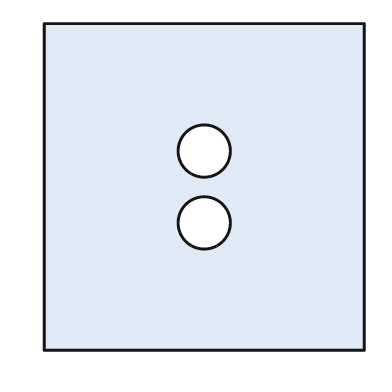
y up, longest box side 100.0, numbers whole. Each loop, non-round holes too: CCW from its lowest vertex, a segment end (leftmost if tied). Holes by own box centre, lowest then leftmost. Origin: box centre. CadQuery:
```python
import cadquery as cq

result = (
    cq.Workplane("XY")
    .moveTo(-49.0, -50.0)
    .lineTo(49.0, -50.0)
    .lineTo(49.0, 50.0)
    .lineTo(-49.0, 50.0)
    .close()
    .moveTo(0.0, -11.0)
    .circle(8.0)
    .moveTo(0.0, 11.0)
    .circle(8.0)
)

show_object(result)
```